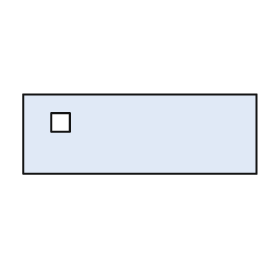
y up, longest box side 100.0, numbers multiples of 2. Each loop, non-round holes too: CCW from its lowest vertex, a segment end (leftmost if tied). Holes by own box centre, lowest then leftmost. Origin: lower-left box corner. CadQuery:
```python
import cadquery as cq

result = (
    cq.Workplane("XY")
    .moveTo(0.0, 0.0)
    .lineTo(100.0, 0.0)
    .lineTo(100.0, 34.0)
    .lineTo(0.0, 34.0)
    .close()
    .moveTo(12.0, 18.0)
    .lineTo(20.0, 18.0)
    .lineTo(20.0, 26.0)
    .lineTo(12.0, 26.0)
    .close()
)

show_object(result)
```